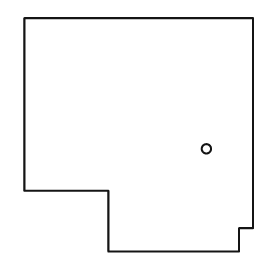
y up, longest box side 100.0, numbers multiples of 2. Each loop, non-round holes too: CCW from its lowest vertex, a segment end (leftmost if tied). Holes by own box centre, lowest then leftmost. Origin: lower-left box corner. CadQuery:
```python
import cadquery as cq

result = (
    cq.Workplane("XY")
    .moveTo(36.0, 0.0)
    .lineTo(92.0, 0.0)
    .lineTo(92.0, 10.0)
    .lineTo(98.0, 10.0)
    .lineTo(98.0, 100.0)
    .lineTo(0.0, 100.0)
    .lineTo(0.0, 26.0)
    .lineTo(36.0, 26.0)
    .close()
    .moveTo(78.0, 44.0)
    .circle(2.0)
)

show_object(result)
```